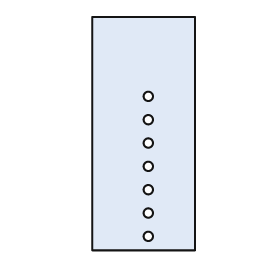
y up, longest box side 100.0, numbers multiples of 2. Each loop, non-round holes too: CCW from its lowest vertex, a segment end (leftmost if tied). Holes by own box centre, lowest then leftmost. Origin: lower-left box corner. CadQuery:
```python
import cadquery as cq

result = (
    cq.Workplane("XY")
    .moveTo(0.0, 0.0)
    .lineTo(44.0, 0.0)
    .lineTo(44.0, 100.0)
    .lineTo(0.0, 100.0)
    .close()
    .moveTo(24.0, 6.0)
    .circle(2.0)
    .moveTo(24.0, 16.0)
    .circle(2.0)
    .moveTo(24.0, 26.0)
    .circle(2.0)
    .moveTo(24.0, 36.0)
    .circle(2.0)
    .moveTo(24.0, 46.0)
    .circle(2.0)
    .moveTo(24.0, 56.0)
    .circle(2.0)
    .moveTo(24.0, 66.0)
    .circle(2.0)
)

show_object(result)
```